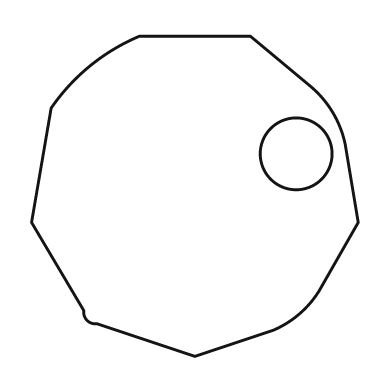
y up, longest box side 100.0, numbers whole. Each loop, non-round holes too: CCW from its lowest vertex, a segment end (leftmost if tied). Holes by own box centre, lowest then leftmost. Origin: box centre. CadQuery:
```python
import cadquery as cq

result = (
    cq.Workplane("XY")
    .moveTo(0.0, -49.0)
    .lineTo(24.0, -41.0)
    .threePointArc((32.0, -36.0), (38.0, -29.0))
    .lineTo(50.0, -8.0)
    .lineTo(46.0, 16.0)
    .threePointArc((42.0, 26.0), (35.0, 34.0))
    .lineTo(17.0, 49.0)
    .lineTo(-17.0, 49.0)
    .threePointArc((-32.0, 40.0), (-44.0, 27.0))
    .lineTo(-50.0, -8.0)
    .lineTo(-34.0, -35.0)
    .threePointArc((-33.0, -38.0), (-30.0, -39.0))
    .close()
    .moveTo(31.0, 13.0)
    .circle(11.0)
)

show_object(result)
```